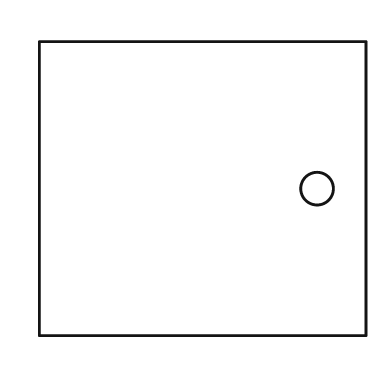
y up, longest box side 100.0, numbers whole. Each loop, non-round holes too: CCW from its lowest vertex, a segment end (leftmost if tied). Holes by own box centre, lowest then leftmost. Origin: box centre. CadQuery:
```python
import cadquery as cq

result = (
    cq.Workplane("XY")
    .moveTo(-50.0, -45.0)
    .lineTo(50.0, -45.0)
    .lineTo(50.0, 45.0)
    .lineTo(-50.0, 45.0)
    .close()
    .moveTo(35.0, 0.0)
    .circle(5.0)
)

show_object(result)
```